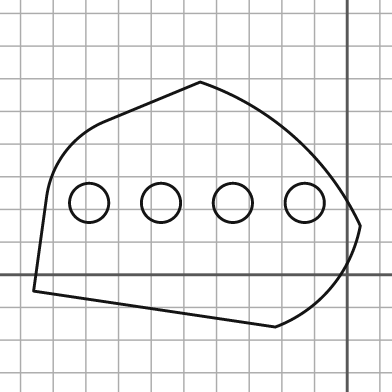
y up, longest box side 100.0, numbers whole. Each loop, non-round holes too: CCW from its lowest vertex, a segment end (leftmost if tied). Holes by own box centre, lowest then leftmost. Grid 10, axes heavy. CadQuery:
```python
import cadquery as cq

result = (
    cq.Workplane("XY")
    .moveTo(-22.0, -16.0)
    .threePointArc((-5.0, -4.0), (4.0, 15.0))
    .threePointArc((-16.0, 42.0), (-45.0, 59.0))
    .lineTo(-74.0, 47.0)
    .threePointArc((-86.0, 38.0), (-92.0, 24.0))
    .lineTo(-96.0, -5.0)
    .close()
    .moveTo(-79.0, 22.0)
    .circle(6.0)
    .moveTo(-57.0, 22.0)
    .circle(6.0)
    .moveTo(-35.0, 22.0)
    .circle(6.0)
    .moveTo(-13.0, 22.0)
    .circle(6.0)
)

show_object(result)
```